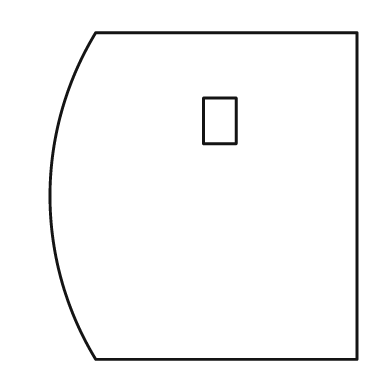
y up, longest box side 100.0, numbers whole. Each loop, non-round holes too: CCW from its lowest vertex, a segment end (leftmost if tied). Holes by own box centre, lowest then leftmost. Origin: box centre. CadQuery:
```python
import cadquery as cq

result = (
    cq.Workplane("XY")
    .moveTo(-33.0, -50.0)
    .lineTo(47.0, -50.0)
    .lineTo(47.0, 50.0)
    .lineTo(-33.0, 50.0)
    .threePointArc((-47.0, 0.0), (-33.0, -50.0))
    .close()
    .moveTo(0.0, 16.0)
    .lineTo(10.0, 16.0)
    .lineTo(10.0, 30.0)
    .lineTo(0.0, 30.0)
    .close()
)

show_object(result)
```